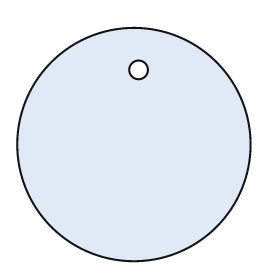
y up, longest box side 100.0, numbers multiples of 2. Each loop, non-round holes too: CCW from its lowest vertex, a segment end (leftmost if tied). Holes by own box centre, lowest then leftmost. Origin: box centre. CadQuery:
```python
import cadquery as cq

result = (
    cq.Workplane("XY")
    .moveTo(0.0, 0.0)
    .circle(50.0)
    .moveTo(2.0, 32.0)
    .circle(4.0)
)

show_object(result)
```